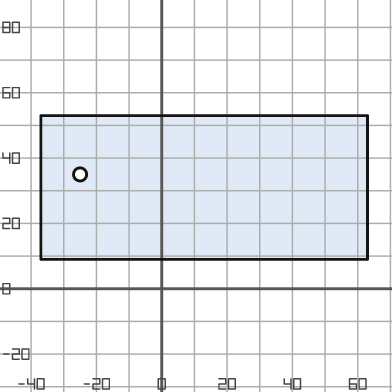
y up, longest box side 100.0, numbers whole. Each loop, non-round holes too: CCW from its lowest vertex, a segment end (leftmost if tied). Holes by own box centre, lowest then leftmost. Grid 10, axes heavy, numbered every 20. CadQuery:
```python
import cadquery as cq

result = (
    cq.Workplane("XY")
    .moveTo(-37.0, 9.0)
    .lineTo(63.0, 9.0)
    .lineTo(63.0, 53.0)
    .lineTo(-37.0, 53.0)
    .close()
    .moveTo(-25.0, 35.0)
    .circle(2.0)
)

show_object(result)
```